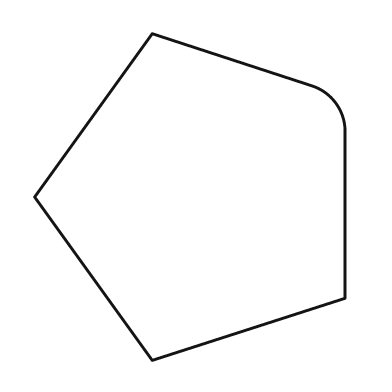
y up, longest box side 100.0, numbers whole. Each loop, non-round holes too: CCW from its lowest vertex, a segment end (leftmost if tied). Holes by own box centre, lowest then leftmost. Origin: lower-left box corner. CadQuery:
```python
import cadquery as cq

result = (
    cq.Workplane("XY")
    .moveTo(36.0, 0.0)
    .lineTo(95.0, 19.0)
    .lineTo(95.0, 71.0)
    .threePointArc((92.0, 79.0), (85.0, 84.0))
    .lineTo(36.0, 100.0)
    .lineTo(0.0, 50.0)
    .close()
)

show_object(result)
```